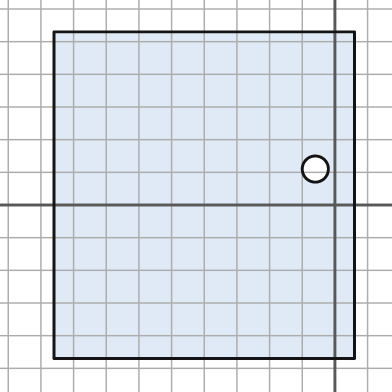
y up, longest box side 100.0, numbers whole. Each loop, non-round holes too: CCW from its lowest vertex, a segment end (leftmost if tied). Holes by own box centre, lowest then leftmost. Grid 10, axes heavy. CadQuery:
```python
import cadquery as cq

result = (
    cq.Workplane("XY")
    .moveTo(-86.0, -47.0)
    .lineTo(6.0, -47.0)
    .lineTo(6.0, 53.0)
    .lineTo(-86.0, 53.0)
    .close()
    .moveTo(-6.0, 11.0)
    .circle(4.0)
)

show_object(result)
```